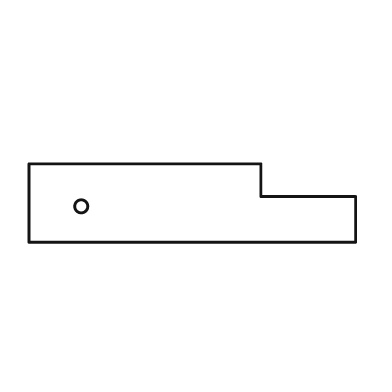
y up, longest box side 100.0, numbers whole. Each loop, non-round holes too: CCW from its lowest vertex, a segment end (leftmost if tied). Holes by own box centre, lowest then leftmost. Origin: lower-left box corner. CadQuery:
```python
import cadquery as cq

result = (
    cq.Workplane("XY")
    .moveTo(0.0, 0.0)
    .lineTo(100.0, 0.0)
    .lineTo(100.0, 14.0)
    .lineTo(71.0, 14.0)
    .lineTo(71.0, 24.0)
    .lineTo(0.0, 24.0)
    .close()
    .moveTo(16.0, 11.0)
    .circle(2.0)
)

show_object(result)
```